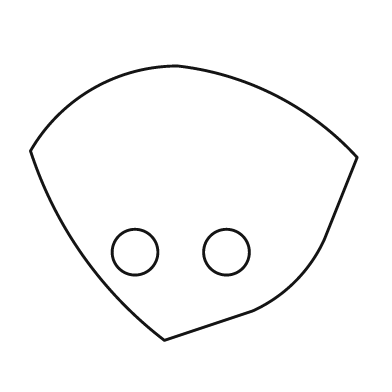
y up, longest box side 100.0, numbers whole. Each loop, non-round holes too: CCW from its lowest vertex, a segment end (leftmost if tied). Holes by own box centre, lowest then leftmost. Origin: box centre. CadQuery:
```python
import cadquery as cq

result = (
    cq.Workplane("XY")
    .moveTo(-9.0, -42.0)
    .lineTo(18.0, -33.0)
    .threePointArc((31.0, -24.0), (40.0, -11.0))
    .lineTo(50.0, 14.0)
    .threePointArc((25.0, 33.0), (-5.0, 42.0))
    .threePointArc((-31.0, 35.0), (-50.0, 16.0))
    .threePointArc((-34.0, -16.0), (-9.0, -42.0))
    .close()
    .moveTo(-18.0, -15.0)
    .circle(7.0)
    .moveTo(10.0, -15.0)
    .circle(7.0)
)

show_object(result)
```